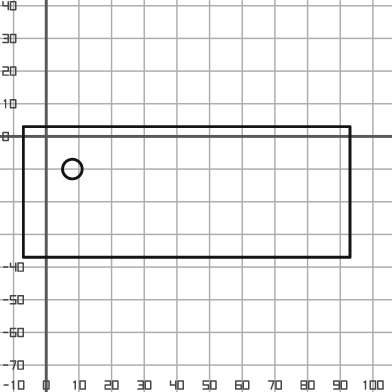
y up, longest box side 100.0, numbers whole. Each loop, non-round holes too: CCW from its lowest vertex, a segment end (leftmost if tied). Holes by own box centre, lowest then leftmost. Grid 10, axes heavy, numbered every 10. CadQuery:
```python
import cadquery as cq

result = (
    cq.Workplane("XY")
    .moveTo(-7.0, -37.0)
    .lineTo(93.0, -37.0)
    .lineTo(93.0, 3.0)
    .lineTo(-7.0, 3.0)
    .close()
    .moveTo(8.0, -10.0)
    .circle(3.0)
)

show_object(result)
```